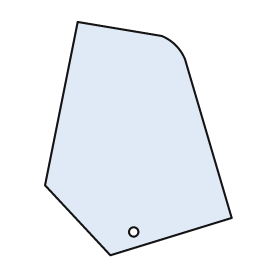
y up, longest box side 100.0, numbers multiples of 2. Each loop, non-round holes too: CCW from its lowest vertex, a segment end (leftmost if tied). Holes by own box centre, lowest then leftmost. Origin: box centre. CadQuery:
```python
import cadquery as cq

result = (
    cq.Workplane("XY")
    .moveTo(-12.0, -50.0)
    .lineTo(40.0, -34.0)
    .lineTo(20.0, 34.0)
    .threePointArc((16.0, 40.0), (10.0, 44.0))
    .lineTo(-26.0, 50.0)
    .lineTo(-40.0, -20.0)
    .close()
    .moveTo(-2.0, -40.0)
    .circle(2.0)
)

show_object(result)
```